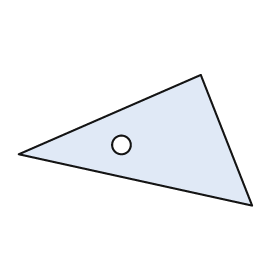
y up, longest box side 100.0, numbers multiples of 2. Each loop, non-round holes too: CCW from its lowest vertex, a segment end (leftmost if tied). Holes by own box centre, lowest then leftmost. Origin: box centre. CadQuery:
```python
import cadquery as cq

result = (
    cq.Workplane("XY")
    .moveTo(50.0, -28.0)
    .lineTo(28.0, 28.0)
    .lineTo(-50.0, -6.0)
    .close()
    .moveTo(-6.0, -2.0)
    .circle(4.0)
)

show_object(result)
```